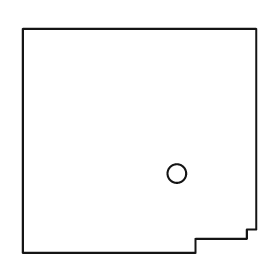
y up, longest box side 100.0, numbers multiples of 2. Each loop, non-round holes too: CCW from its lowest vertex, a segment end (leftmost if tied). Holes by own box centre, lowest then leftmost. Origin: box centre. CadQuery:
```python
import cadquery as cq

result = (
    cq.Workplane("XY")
    .moveTo(-50.0, -48.0)
    .lineTo(24.0, -48.0)
    .lineTo(24.0, -42.0)
    .lineTo(46.0, -42.0)
    .lineTo(46.0, -38.0)
    .lineTo(50.0, -38.0)
    .lineTo(50.0, 48.0)
    .lineTo(-50.0, 48.0)
    .close()
    .moveTo(16.0, -14.0)
    .circle(4.0)
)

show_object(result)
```